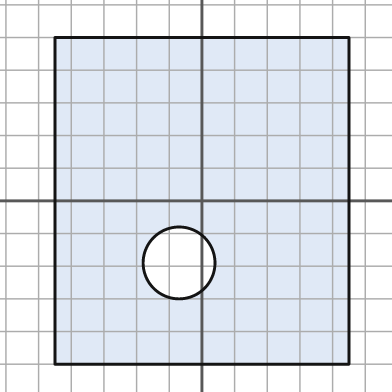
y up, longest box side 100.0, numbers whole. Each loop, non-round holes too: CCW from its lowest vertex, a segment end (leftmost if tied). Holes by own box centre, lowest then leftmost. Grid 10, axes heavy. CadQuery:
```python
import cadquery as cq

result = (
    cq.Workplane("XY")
    .moveTo(-45.0, -50.0)
    .lineTo(45.0, -50.0)
    .lineTo(45.0, 50.0)
    .lineTo(-45.0, 50.0)
    .close()
    .moveTo(-7.0, -19.0)
    .circle(11.0)
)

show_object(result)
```